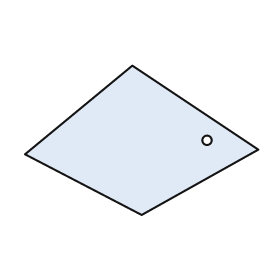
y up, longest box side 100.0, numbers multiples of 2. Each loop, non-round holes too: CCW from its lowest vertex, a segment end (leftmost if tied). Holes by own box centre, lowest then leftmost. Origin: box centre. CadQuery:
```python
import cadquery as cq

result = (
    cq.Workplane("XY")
    .moveTo(0.0, -32.0)
    .lineTo(50.0, -4.0)
    .lineTo(-4.0, 32.0)
    .lineTo(-50.0, -6.0)
    .close()
    .moveTo(28.0, 0.0)
    .circle(2.0)
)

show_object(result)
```